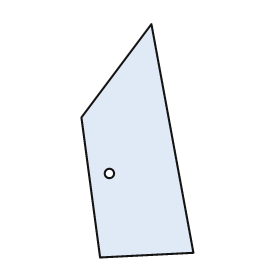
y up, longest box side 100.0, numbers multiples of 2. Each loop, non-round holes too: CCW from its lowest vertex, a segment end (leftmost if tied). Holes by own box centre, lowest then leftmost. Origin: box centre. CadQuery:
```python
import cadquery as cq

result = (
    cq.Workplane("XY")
    .moveTo(-16.0, -50.0)
    .lineTo(24.0, -48.0)
    .lineTo(6.0, 50.0)
    .lineTo(-24.0, 10.0)
    .close()
    .moveTo(-12.0, -14.0)
    .circle(2.0)
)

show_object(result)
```